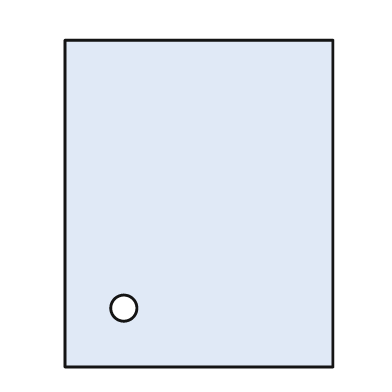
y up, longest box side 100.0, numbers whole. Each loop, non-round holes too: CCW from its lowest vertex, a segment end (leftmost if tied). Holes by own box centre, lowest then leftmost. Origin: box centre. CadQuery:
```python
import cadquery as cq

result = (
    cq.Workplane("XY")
    .moveTo(-41.0, -50.0)
    .lineTo(41.0, -50.0)
    .lineTo(41.0, 50.0)
    .lineTo(-41.0, 50.0)
    .close()
    .moveTo(-23.0, -32.0)
    .circle(4.0)
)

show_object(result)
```